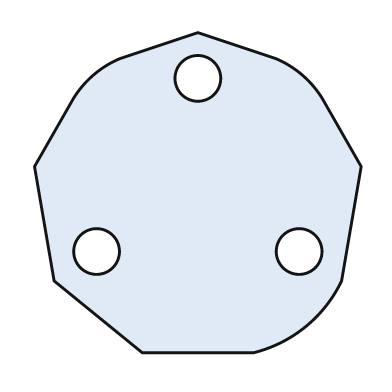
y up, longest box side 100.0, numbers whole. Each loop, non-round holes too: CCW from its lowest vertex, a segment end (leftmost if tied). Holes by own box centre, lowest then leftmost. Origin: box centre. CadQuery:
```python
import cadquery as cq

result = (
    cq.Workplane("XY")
    .moveTo(-17.0, -49.0)
    .lineTo(17.0, -49.0)
    .threePointArc((33.0, -41.0), (44.0, -27.0))
    .lineTo(50.0, 8.0)
    .lineTo(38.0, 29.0)
    .threePointArc((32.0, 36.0), (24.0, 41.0))
    .lineTo(0.0, 49.0)
    .lineTo(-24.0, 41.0)
    .threePointArc((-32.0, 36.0), (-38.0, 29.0))
    .lineTo(-50.0, 8.0)
    .lineTo(-44.0, -27.0)
    .close()
    .moveTo(-31.0, -18.0)
    .circle(7.0)
    .moveTo(31.0, -18.0)
    .circle(7.0)
    .moveTo(0.0, 35.0)
    .circle(7.0)
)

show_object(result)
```